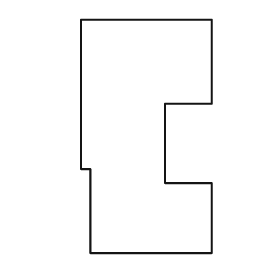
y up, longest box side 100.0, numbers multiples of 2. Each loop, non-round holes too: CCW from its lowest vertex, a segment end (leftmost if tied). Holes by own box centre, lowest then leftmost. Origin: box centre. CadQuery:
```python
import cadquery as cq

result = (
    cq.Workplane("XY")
    .moveTo(-24.0, -50.0)
    .lineTo(28.0, -50.0)
    .lineTo(28.0, -20.0)
    .lineTo(8.0, -20.0)
    .lineTo(8.0, 14.0)
    .lineTo(28.0, 14.0)
    .lineTo(28.0, 50.0)
    .lineTo(-28.0, 50.0)
    .lineTo(-28.0, -14.0)
    .lineTo(-24.0, -14.0)
    .close()
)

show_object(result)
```